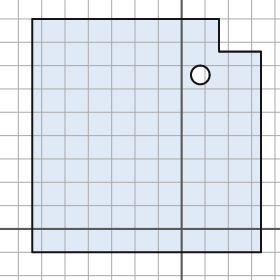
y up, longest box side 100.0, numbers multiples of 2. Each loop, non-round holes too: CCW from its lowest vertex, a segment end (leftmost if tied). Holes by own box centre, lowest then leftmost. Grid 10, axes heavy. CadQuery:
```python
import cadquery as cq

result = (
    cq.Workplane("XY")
    .moveTo(-64.0, -10.0)
    .lineTo(34.0, -10.0)
    .lineTo(34.0, 76.0)
    .lineTo(16.0, 76.0)
    .lineTo(16.0, 90.0)
    .lineTo(-64.0, 90.0)
    .close()
    .moveTo(8.0, 66.0)
    .circle(4.0)
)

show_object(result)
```